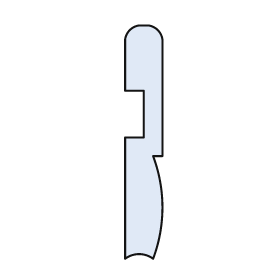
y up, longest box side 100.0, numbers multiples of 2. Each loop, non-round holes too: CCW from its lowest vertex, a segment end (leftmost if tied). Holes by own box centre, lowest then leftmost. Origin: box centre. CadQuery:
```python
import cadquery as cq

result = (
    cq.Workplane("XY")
    .moveTo(-8.0, -50.0)
    .threePointArc((-2.0, -48.0), (4.0, -50.0))
    .threePointArc((8.0, -28.0), (4.0, -6.0))
    .lineTo(8.0, -6.0)
    .lineTo(8.0, 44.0)
    .threePointArc((6.0, 48.0), (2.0, 50.0))
    .lineTo(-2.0, 50.0)
    .threePointArc((-6.0, 48.0), (-8.0, 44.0))
    .lineTo(-8.0, 22.0)
    .lineTo(0.0, 22.0)
    .lineTo(0.0, 2.0)
    .lineTo(-8.0, 2.0)
    .close()
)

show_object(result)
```